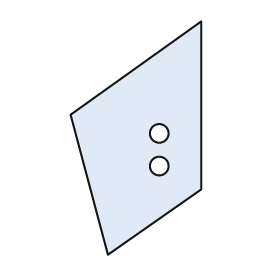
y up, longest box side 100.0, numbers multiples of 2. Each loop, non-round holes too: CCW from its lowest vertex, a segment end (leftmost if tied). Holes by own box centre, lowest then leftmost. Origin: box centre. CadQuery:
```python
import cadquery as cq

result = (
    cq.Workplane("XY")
    .moveTo(-12.0, -50.0)
    .lineTo(28.0, -22.0)
    .lineTo(28.0, 50.0)
    .lineTo(-28.0, 10.0)
    .close()
    .moveTo(10.0, -12.0)
    .circle(4.0)
    .moveTo(10.0, 2.0)
    .circle(4.0)
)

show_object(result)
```